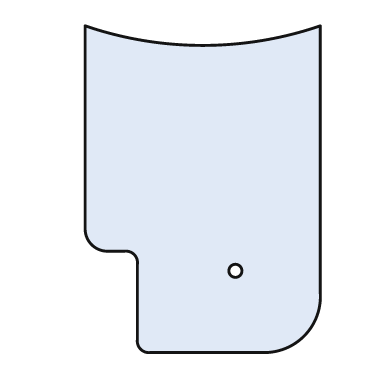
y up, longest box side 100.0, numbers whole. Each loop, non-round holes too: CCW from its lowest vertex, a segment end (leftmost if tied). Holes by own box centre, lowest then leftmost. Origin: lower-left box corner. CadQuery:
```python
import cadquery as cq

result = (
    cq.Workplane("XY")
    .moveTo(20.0, 0.0)
    .lineTo(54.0, 0.0)
    .threePointArc((67.0, 5.0), (72.0, 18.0))
    .lineTo(72.0, 100.0)
    .threePointArc((36.0, 94.0), (0.0, 100.0))
    .lineTo(0.0, 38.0)
    .threePointArc((2.0, 33.0), (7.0, 31.0))
    .lineTo(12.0, 31.0)
    .threePointArc((15.0, 30.0), (16.0, 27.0))
    .lineTo(16.0, 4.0)
    .threePointArc((17.0, 1.0), (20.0, 0.0))
    .close()
    .moveTo(46.0, 25.0)
    .circle(2.0)
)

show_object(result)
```